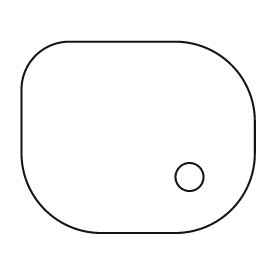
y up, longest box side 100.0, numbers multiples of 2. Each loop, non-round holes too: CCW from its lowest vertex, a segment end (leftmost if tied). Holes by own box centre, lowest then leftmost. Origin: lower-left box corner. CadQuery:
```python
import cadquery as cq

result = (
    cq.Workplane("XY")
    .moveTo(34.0, 0.0)
    .lineTo(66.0, 0.0)
    .threePointArc((90.0, 10.0), (100.0, 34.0))
    .lineTo(100.0, 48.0)
    .threePointArc((90.0, 72.0), (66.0, 82.0))
    .lineTo(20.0, 82.0)
    .threePointArc((6.0, 76.0), (0.0, 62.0))
    .lineTo(0.0, 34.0)
    .threePointArc((10.0, 10.0), (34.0, 0.0))
    .close()
    .moveTo(72.0, 24.0)
    .circle(6.0)
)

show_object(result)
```